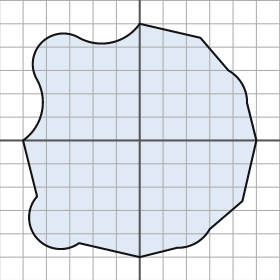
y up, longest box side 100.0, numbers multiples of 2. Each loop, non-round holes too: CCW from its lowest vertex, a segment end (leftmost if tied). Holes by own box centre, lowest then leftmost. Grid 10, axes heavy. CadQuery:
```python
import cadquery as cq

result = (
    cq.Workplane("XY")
    .moveTo(0.0, -50.0)
    .lineTo(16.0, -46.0)
    .threePointArc((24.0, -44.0), (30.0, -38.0))
    .lineTo(44.0, -26.0)
    .lineTo(50.0, 0.0)
    .lineTo(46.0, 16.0)
    .threePointArc((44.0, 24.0), (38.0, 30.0))
    .lineTo(26.0, 44.0)
    .lineTo(0.0, 50.0)
    .threePointArc((-12.0, 42.0), (-26.0, 44.0))
    .threePointArc((-42.0, 42.0), (-44.0, 26.0))
    .threePointArc((-42.0, 12.0), (-50.0, 0.0))
    .lineTo(-44.0, -24.0)
    .threePointArc((-44.0, -42.0), (-26.0, -44.0))
    .close()
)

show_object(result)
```